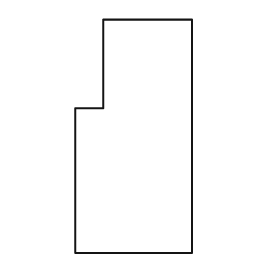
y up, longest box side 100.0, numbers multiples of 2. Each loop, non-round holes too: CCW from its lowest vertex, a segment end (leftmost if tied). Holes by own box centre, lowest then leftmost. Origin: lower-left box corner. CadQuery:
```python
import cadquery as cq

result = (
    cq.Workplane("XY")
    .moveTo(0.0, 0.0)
    .lineTo(50.0, 0.0)
    .lineTo(50.0, 100.0)
    .lineTo(12.0, 100.0)
    .lineTo(12.0, 62.0)
    .lineTo(0.0, 62.0)
    .close()
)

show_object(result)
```